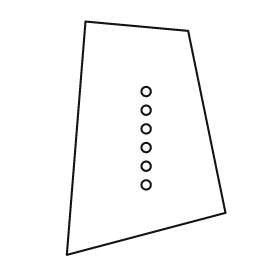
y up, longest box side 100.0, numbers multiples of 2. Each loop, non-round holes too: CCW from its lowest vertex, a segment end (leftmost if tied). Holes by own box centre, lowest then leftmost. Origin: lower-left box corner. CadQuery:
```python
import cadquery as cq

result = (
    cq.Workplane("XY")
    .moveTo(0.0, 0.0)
    .lineTo(68.0, 18.0)
    .lineTo(52.0, 96.0)
    .lineTo(8.0, 100.0)
    .close()
    .moveTo(34.0, 30.0)
    .circle(2.0)
    .moveTo(34.0, 38.0)
    .circle(2.0)
    .moveTo(34.0, 46.0)
    .circle(2.0)
    .moveTo(34.0, 54.0)
    .circle(2.0)
    .moveTo(34.0, 62.0)
    .circle(2.0)
    .moveTo(34.0, 70.0)
    .circle(2.0)
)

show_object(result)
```